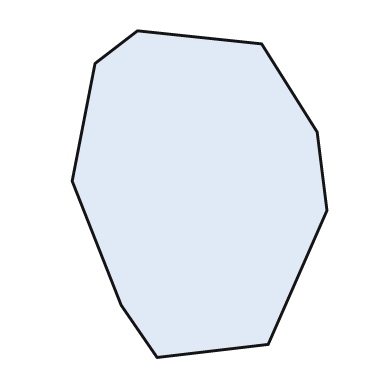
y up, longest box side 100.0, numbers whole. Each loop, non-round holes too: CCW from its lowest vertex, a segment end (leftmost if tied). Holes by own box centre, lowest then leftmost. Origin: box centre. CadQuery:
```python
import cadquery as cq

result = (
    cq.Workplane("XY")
    .moveTo(-13.0, -50.0)
    .lineTo(21.0, -46.0)
    .lineTo(39.0, -5.0)
    .lineTo(36.0, 19.0)
    .lineTo(19.0, 46.0)
    .lineTo(-19.0, 50.0)
    .lineTo(-32.0, 40.0)
    .lineTo(-39.0, 4.0)
    .lineTo(-24.0, -34.0)
    .close()
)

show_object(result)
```